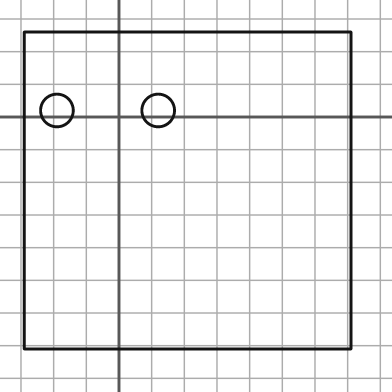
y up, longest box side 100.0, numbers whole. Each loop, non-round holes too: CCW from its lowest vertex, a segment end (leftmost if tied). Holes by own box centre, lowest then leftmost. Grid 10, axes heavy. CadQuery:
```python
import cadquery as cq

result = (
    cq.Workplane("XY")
    .moveTo(-29.0, -71.0)
    .lineTo(71.0, -71.0)
    .lineTo(71.0, 26.0)
    .lineTo(-29.0, 26.0)
    .close()
    .moveTo(-19.0, 2.0)
    .circle(5.0)
    .moveTo(12.0, 2.0)
    .circle(5.0)
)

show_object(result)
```